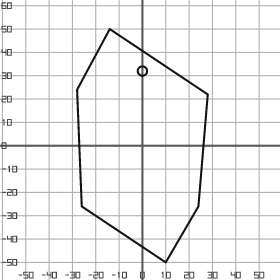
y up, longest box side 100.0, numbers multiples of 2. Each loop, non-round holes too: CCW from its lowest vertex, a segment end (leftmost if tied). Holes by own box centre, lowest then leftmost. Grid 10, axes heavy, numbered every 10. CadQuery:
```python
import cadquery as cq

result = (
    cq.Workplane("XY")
    .moveTo(10.0, -50.0)
    .lineTo(24.0, -26.0)
    .lineTo(28.0, 22.0)
    .lineTo(-14.0, 50.0)
    .lineTo(-28.0, 24.0)
    .lineTo(-26.0, -26.0)
    .close()
    .moveTo(0.0, 32.0)
    .circle(2.0)
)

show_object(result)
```